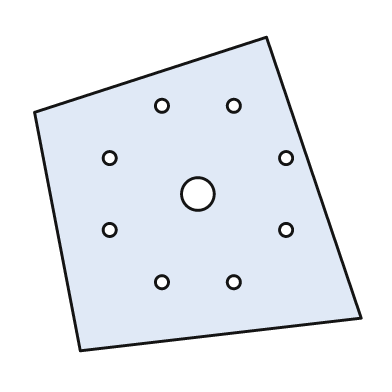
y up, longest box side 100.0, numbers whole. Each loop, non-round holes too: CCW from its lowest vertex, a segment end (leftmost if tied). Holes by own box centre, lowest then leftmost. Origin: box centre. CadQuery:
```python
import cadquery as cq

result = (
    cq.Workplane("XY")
    .moveTo(-36.0, -48.0)
    .lineTo(50.0, -38.0)
    .lineTo(21.0, 48.0)
    .lineTo(-50.0, 25.0)
    .close()
    .moveTo(-11.0, -27.0)
    .circle(2.0)
    .moveTo(11.0, -27.0)
    .circle(2.0)
    .moveTo(-27.0, -11.0)
    .circle(2.0)
    .moveTo(27.0, -11.0)
    .circle(2.0)
    .moveTo(0.0, 0.0)
    .circle(5.0)
    .moveTo(-27.0, 11.0)
    .circle(2.0)
    .moveTo(27.0, 11.0)
    .circle(2.0)
    .moveTo(-11.0, 27.0)
    .circle(2.0)
    .moveTo(11.0, 27.0)
    .circle(2.0)
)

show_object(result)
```